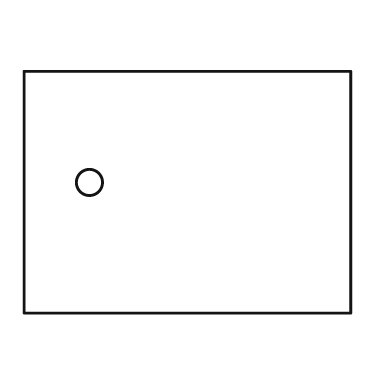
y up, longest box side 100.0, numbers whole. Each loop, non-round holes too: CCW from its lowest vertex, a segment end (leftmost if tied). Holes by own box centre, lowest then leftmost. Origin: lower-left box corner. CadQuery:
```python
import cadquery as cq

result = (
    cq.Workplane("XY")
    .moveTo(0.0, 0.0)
    .lineTo(100.0, 0.0)
    .lineTo(100.0, 74.0)
    .lineTo(0.0, 74.0)
    .close()
    .moveTo(20.0, 40.0)
    .circle(4.0)
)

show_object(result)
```